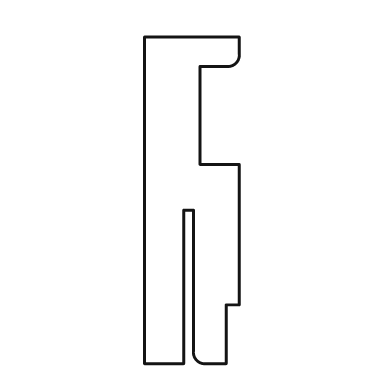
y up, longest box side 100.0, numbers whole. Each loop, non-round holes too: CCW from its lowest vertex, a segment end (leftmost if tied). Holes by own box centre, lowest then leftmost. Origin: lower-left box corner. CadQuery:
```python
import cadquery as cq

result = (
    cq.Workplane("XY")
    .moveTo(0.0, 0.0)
    .lineTo(12.0, 0.0)
    .lineTo(12.0, 47.0)
    .lineTo(15.0, 47.0)
    .lineTo(15.0, 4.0)
    .threePointArc((16.0, 1.0), (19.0, 0.0))
    .lineTo(25.0, 0.0)
    .lineTo(25.0, 18.0)
    .lineTo(29.0, 18.0)
    .lineTo(29.0, 61.0)
    .lineTo(17.0, 61.0)
    .lineTo(17.0, 91.0)
    .lineTo(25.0, 91.0)
    .threePointArc((28.0, 92.0), (29.0, 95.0))
    .lineTo(29.0, 100.0)
    .lineTo(0.0, 100.0)
    .close()
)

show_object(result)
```